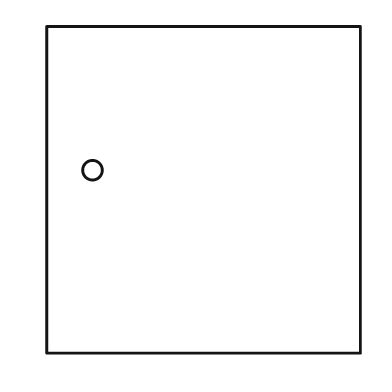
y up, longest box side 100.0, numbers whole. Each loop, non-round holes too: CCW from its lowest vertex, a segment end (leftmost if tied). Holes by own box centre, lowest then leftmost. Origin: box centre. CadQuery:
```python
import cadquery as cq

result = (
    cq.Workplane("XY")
    .moveTo(-48.0, -50.0)
    .lineTo(48.0, -50.0)
    .lineTo(48.0, 50.0)
    .lineTo(-48.0, 50.0)
    .close()
    .moveTo(-34.0, 6.0)
    .circle(3.0)
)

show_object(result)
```